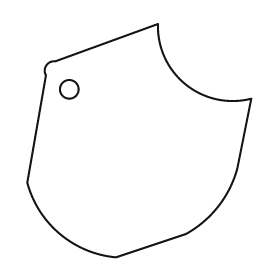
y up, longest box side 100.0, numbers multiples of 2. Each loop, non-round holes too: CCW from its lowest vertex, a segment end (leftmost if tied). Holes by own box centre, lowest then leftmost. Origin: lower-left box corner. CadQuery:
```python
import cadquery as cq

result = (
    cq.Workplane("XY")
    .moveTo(38.0, 0.0)
    .lineTo(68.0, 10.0)
    .threePointArc((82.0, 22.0), (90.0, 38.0))
    .lineTo(96.0, 68.0)
    .threePointArc((68.0, 74.0), (56.0, 100.0))
    .lineTo(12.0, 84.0)
    .threePointArc((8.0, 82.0), (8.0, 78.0))
    .lineTo(0.0, 32.0)
    .threePointArc((14.0, 10.0), (38.0, 0.0))
    .close()
    .moveTo(18.0, 72.0)
    .circle(4.0)
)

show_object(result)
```